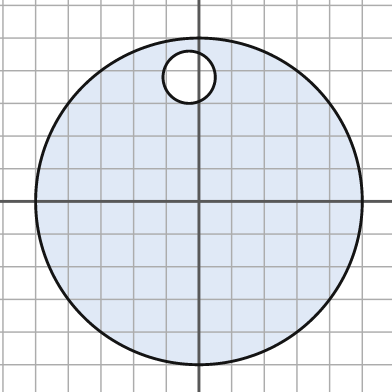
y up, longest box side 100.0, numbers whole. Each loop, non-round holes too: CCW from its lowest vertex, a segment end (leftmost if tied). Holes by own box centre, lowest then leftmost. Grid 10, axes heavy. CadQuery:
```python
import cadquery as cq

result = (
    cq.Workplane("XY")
    .moveTo(0.0, 0.0)
    .circle(50.0)
    .moveTo(-3.0, 38.0)
    .circle(8.0)
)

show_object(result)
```